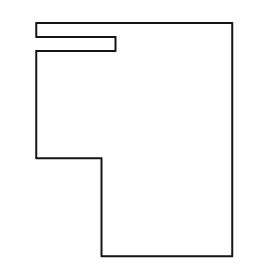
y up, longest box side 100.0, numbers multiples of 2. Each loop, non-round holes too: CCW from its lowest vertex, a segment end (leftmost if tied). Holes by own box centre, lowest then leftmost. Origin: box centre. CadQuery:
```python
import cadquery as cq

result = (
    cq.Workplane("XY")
    .moveTo(-14.0, -50.0)
    .lineTo(42.0, -50.0)
    .lineTo(42.0, 50.0)
    .lineTo(-42.0, 50.0)
    .lineTo(-42.0, 44.0)
    .lineTo(-8.0, 44.0)
    .lineTo(-8.0, 38.0)
    .lineTo(-42.0, 38.0)
    .lineTo(-42.0, -8.0)
    .lineTo(-14.0, -8.0)
    .close()
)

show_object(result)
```